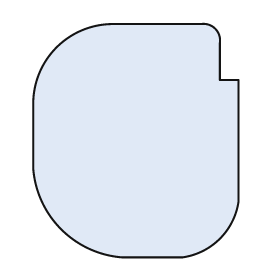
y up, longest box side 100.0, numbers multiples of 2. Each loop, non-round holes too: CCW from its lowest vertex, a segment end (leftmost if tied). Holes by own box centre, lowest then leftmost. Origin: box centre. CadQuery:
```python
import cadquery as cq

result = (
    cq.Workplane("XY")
    .moveTo(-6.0, -50.0)
    .lineTo(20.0, -50.0)
    .threePointArc((36.0, -42.0), (44.0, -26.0))
    .lineTo(44.0, 26.0)
    .lineTo(36.0, 26.0)
    .lineTo(36.0, 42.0)
    .threePointArc((34.0, 48.0), (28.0, 50.0))
    .lineTo(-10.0, 50.0)
    .threePointArc((-34.0, 40.0), (-44.0, 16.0))
    .lineTo(-44.0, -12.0)
    .threePointArc((-32.0, -38.0), (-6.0, -50.0))
    .close()
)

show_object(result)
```